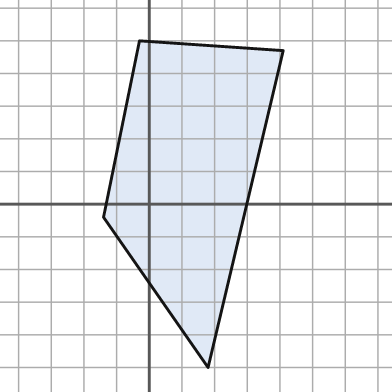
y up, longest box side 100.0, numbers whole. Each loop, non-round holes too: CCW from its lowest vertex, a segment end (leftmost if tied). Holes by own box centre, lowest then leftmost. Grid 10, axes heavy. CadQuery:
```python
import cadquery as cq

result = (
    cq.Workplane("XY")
    .moveTo(18.0, -50.0)
    .lineTo(41.0, 47.0)
    .lineTo(-3.0, 50.0)
    .lineTo(-14.0, -4.0)
    .close()
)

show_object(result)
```